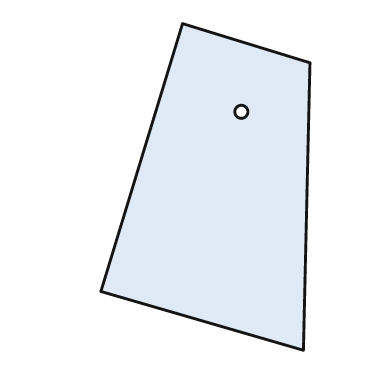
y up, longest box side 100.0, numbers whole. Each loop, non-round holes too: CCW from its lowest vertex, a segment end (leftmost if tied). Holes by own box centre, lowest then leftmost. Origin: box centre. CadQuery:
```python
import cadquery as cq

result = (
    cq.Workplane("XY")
    .moveTo(30.0, -50.0)
    .lineTo(32.0, 38.0)
    .lineTo(-7.0, 50.0)
    .lineTo(-32.0, -32.0)
    .close()
    .moveTo(11.0, 23.0)
    .circle(2.0)
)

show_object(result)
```